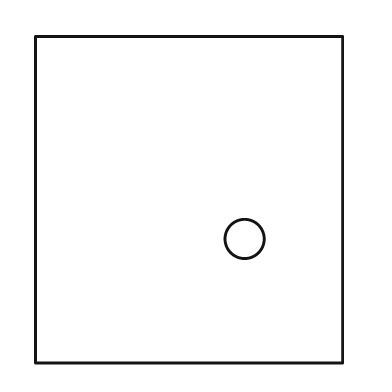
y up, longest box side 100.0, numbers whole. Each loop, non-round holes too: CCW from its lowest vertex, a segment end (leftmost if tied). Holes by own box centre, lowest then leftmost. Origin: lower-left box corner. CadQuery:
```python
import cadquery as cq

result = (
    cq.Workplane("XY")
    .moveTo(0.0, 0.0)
    .lineTo(94.0, 0.0)
    .lineTo(94.0, 100.0)
    .lineTo(0.0, 100.0)
    .close()
    .moveTo(64.0, 38.0)
    .circle(6.0)
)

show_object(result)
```